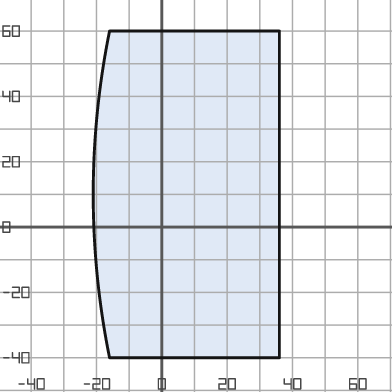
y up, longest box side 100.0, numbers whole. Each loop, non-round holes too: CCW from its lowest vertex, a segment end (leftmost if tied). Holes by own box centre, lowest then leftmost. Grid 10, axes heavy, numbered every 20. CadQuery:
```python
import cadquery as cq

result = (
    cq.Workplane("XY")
    .moveTo(-16.0, -40.0)
    .lineTo(36.0, -40.0)
    .lineTo(36.0, 60.0)
    .lineTo(-16.0, 60.0)
    .threePointArc((-21.0, 10.0), (-16.0, -40.0))
    .close()
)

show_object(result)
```